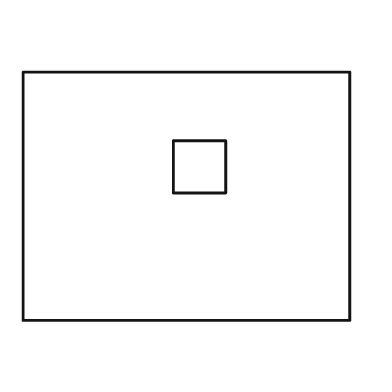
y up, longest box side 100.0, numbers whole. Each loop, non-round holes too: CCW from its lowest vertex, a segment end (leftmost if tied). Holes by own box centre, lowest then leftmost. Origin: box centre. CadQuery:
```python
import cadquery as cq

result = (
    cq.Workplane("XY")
    .moveTo(-50.0, -38.0)
    .lineTo(50.0, -38.0)
    .lineTo(50.0, 38.0)
    .lineTo(-50.0, 38.0)
    .close()
    .moveTo(-4.0, 1.0)
    .lineTo(12.0, 1.0)
    .lineTo(12.0, 17.0)
    .lineTo(-4.0, 17.0)
    .close()
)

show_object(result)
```